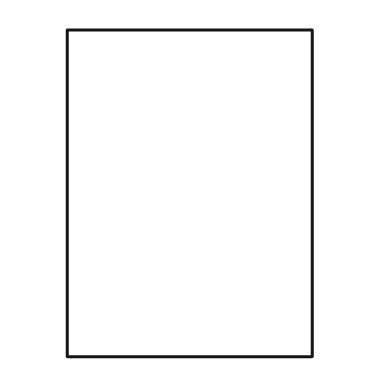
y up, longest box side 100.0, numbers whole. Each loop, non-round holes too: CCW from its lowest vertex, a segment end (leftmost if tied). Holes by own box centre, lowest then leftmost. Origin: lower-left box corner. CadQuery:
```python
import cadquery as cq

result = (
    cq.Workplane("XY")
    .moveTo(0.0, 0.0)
    .lineTo(75.0, 0.0)
    .lineTo(75.0, 100.0)
    .lineTo(0.0, 100.0)
    .close()
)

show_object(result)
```